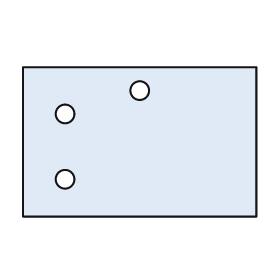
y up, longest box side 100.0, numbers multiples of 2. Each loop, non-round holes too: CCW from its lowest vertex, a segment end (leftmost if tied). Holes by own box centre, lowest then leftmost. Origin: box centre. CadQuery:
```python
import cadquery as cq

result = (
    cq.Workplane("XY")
    .moveTo(-50.0, -32.0)
    .lineTo(50.0, -32.0)
    .lineTo(50.0, 32.0)
    .lineTo(-50.0, 32.0)
    .close()
    .moveTo(-32.0, -16.0)
    .circle(4.0)
    .moveTo(-32.0, 12.0)
    .circle(4.0)
    .moveTo(0.0, 22.0)
    .circle(4.0)
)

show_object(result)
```